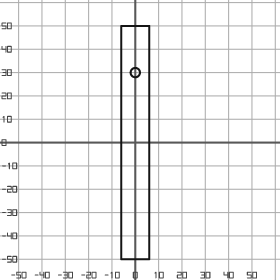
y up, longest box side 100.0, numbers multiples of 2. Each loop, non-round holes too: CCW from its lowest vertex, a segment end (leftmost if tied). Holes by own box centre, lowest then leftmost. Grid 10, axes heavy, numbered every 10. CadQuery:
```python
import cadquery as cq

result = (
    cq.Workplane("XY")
    .moveTo(-6.0, -50.0)
    .lineTo(6.0, -50.0)
    .lineTo(6.0, 50.0)
    .lineTo(-6.0, 50.0)
    .close()
    .moveTo(0.0, 30.0)
    .circle(2.0)
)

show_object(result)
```